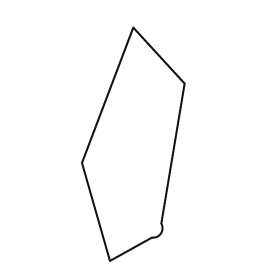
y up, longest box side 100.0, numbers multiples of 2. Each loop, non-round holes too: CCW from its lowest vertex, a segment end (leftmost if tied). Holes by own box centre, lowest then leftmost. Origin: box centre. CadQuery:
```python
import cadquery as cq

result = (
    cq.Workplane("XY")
    .moveTo(-10.0, -50.0)
    .lineTo(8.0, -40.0)
    .threePointArc((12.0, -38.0), (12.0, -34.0))
    .lineTo(22.0, 26.0)
    .lineTo(0.0, 50.0)
    .lineTo(-22.0, -8.0)
    .close()
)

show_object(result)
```